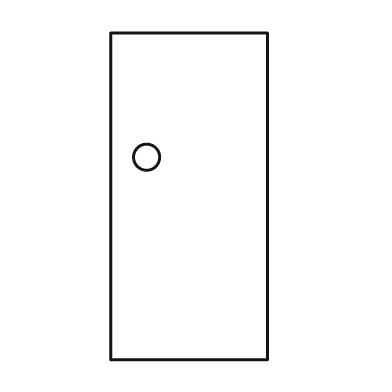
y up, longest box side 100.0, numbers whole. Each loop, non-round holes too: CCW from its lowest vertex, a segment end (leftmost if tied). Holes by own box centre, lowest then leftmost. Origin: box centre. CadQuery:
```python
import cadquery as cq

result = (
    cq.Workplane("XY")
    .moveTo(-24.0, -50.0)
    .lineTo(24.0, -50.0)
    .lineTo(24.0, 50.0)
    .lineTo(-24.0, 50.0)
    .close()
    .moveTo(-13.0, 12.0)
    .circle(4.0)
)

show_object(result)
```